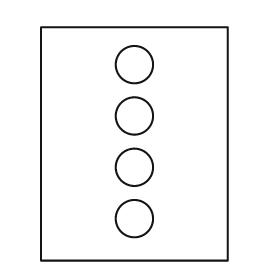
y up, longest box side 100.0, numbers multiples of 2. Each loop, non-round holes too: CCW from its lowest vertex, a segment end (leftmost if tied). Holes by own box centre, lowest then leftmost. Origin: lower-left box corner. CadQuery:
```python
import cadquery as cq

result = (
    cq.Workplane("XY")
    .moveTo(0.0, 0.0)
    .lineTo(80.0, 0.0)
    .lineTo(80.0, 100.0)
    .lineTo(0.0, 100.0)
    .close()
    .moveTo(40.0, 18.0)
    .circle(8.0)
    .moveTo(40.0, 40.0)
    .circle(8.0)
    .moveTo(40.0, 62.0)
    .circle(8.0)
    .moveTo(40.0, 84.0)
    .circle(8.0)
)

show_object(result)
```